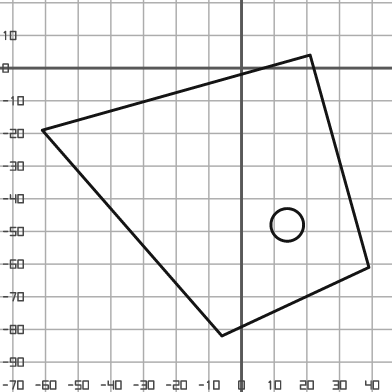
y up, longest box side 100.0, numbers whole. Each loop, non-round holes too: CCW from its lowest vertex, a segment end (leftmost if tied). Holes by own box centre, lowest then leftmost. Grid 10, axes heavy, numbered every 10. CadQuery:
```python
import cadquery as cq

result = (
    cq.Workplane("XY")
    .moveTo(-6.0, -82.0)
    .lineTo(39.0, -61.0)
    .lineTo(21.0, 4.0)
    .lineTo(-61.0, -19.0)
    .close()
    .moveTo(14.0, -48.0)
    .circle(5.0)
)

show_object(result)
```